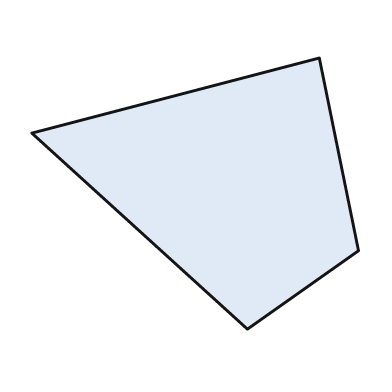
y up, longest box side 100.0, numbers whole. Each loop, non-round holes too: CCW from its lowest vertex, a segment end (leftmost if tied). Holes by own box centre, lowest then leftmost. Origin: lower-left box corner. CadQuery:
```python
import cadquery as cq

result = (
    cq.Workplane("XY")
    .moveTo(66.0, 0.0)
    .lineTo(100.0, 24.0)
    .lineTo(88.0, 83.0)
    .lineTo(0.0, 60.0)
    .close()
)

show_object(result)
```